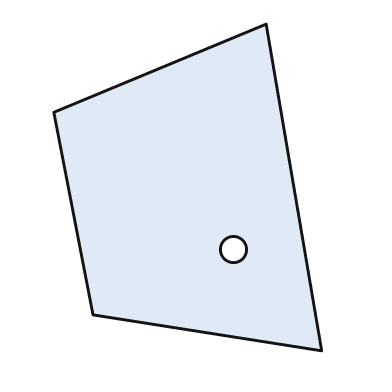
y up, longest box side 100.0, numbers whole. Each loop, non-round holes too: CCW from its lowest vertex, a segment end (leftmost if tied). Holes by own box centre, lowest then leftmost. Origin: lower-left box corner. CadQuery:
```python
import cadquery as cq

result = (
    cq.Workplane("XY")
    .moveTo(82.0, 0.0)
    .lineTo(65.0, 100.0)
    .lineTo(0.0, 73.0)
    .lineTo(12.0, 11.0)
    .close()
    .moveTo(55.0, 31.0)
    .circle(4.0)
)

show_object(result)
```